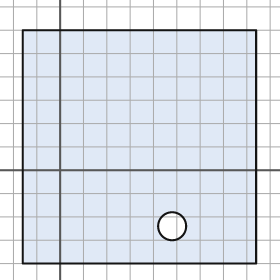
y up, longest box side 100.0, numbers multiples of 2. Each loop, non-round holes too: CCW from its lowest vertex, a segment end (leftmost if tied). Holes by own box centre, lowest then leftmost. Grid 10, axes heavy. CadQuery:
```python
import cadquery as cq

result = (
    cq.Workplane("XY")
    .moveTo(-16.0, -40.0)
    .lineTo(84.0, -40.0)
    .lineTo(84.0, 60.0)
    .lineTo(-16.0, 60.0)
    .close()
    .moveTo(48.0, -24.0)
    .circle(6.0)
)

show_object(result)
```